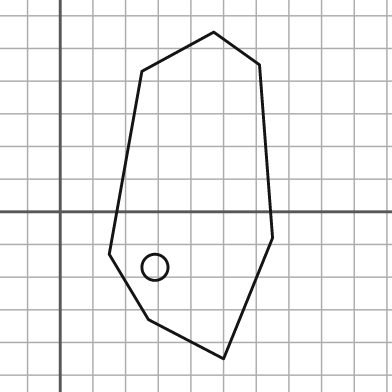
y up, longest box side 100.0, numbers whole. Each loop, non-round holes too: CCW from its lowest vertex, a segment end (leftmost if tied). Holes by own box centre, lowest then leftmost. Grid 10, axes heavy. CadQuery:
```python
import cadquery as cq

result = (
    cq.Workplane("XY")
    .moveTo(50.0, -45.0)
    .lineTo(65.0, -8.0)
    .lineTo(61.0, 45.0)
    .lineTo(47.0, 55.0)
    .lineTo(25.0, 43.0)
    .lineTo(15.0, -13.0)
    .lineTo(27.0, -33.0)
    .close()
    .moveTo(29.0, -17.0)
    .circle(4.0)
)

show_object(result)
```